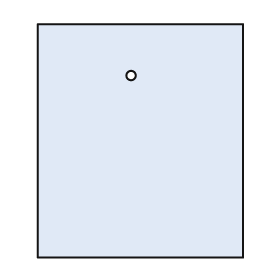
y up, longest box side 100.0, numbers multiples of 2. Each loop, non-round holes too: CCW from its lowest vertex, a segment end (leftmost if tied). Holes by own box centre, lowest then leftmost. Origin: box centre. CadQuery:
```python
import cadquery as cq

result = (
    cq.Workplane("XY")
    .moveTo(-44.0, -50.0)
    .lineTo(44.0, -50.0)
    .lineTo(44.0, 50.0)
    .lineTo(-44.0, 50.0)
    .close()
    .moveTo(-4.0, 28.0)
    .circle(2.0)
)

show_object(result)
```